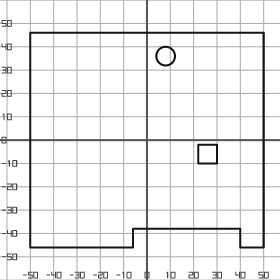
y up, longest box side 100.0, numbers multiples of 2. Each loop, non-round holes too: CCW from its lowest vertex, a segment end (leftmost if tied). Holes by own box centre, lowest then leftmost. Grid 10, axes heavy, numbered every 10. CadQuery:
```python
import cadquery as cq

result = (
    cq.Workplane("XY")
    .moveTo(-50.0, -46.0)
    .lineTo(-6.0, -46.0)
    .lineTo(-6.0, -38.0)
    .lineTo(40.0, -38.0)
    .lineTo(40.0, -46.0)
    .lineTo(50.0, -46.0)
    .lineTo(50.0, 46.0)
    .lineTo(-50.0, 46.0)
    .close()
    .moveTo(22.0, -10.0)
    .lineTo(30.0, -10.0)
    .lineTo(30.0, -2.0)
    .lineTo(22.0, -2.0)
    .close()
    .moveTo(8.0, 36.0)
    .circle(4.0)
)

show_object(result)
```